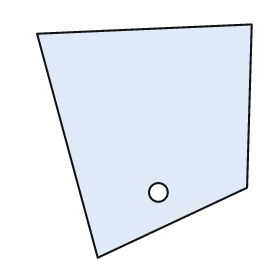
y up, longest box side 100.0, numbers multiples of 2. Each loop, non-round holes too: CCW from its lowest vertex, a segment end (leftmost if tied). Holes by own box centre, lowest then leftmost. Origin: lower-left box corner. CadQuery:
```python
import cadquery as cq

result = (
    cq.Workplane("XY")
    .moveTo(26.0, 0.0)
    .lineTo(90.0, 30.0)
    .lineTo(92.0, 100.0)
    .lineTo(0.0, 96.0)
    .close()
    .moveTo(52.0, 28.0)
    .circle(4.0)
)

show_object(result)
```